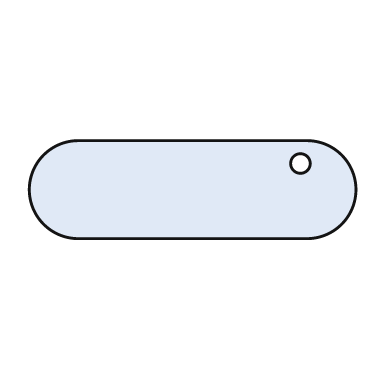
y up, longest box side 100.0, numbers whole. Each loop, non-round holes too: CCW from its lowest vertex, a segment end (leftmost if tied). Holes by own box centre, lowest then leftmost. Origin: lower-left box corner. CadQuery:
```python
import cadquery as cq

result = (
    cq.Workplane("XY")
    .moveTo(15.0, 0.0)
    .lineTo(85.0, 0.0)
    .threePointArc((100.0, 15.0), (85.0, 30.0))
    .lineTo(15.0, 30.0)
    .threePointArc((0.0, 15.0), (15.0, 0.0))
    .close()
    .moveTo(83.0, 23.0)
    .circle(3.0)
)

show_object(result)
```